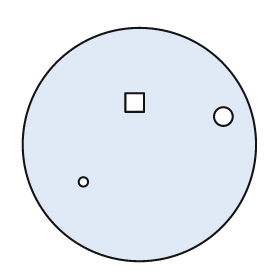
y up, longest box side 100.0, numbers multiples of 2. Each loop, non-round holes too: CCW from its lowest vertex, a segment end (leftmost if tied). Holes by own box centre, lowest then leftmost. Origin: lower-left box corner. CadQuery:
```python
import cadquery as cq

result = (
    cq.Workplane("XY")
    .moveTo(50.0, 50.0)
    .circle(50.0)
    .moveTo(26.0, 34.0)
    .circle(2.0)
    .moveTo(86.0, 62.0)
    .circle(4.0)
    .moveTo(44.0, 64.0)
    .lineTo(52.0, 64.0)
    .lineTo(52.0, 72.0)
    .lineTo(44.0, 72.0)
    .close()
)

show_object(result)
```